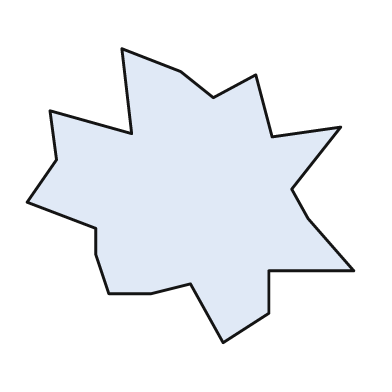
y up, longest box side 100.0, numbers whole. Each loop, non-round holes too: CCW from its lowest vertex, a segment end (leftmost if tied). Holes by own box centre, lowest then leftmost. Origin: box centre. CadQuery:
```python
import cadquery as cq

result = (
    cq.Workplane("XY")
    .moveTo(10.0, -45.0)
    .lineTo(24.0, -36.0)
    .lineTo(24.0, -23.0)
    .lineTo(50.0, -23.0)
    .lineTo(36.0, -7.0)
    .lineTo(31.0, 2.0)
    .lineTo(46.0, 21.0)
    .lineTo(25.0, 18.0)
    .lineTo(20.0, 37.0)
    .lineTo(7.0, 30.0)
    .lineTo(-3.0, 38.0)
    .lineTo(-21.0, 45.0)
    .lineTo(-18.0, 19.0)
    .lineTo(-43.0, 26.0)
    .lineTo(-41.0, 11.0)
    .lineTo(-50.0, -2.0)
    .lineTo(-29.0, -10.0)
    .lineTo(-29.0, -18.0)
    .lineTo(-25.0, -30.0)
    .lineTo(-12.0, -30.0)
    .lineTo(0.0, -27.0)
    .close()
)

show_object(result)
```